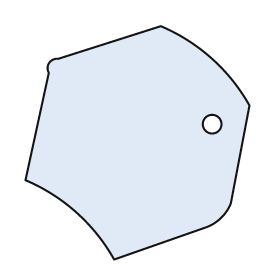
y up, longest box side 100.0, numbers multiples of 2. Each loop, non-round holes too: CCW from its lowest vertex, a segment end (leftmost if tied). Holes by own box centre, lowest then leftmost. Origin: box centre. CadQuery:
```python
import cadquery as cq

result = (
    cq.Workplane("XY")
    .moveTo(-10.0, -50.0)
    .lineTo(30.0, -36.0)
    .threePointArc((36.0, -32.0), (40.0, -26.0))
    .lineTo(48.0, 16.0)
    .threePointArc((32.0, 36.0), (10.0, 50.0))
    .lineTo(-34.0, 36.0)
    .threePointArc((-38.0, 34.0), (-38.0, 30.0))
    .lineTo(-48.0, -16.0)
    .threePointArc((-26.0, -30.0), (-10.0, -50.0))
    .close()
    .moveTo(32.0, 8.0)
    .circle(4.0)
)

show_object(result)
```